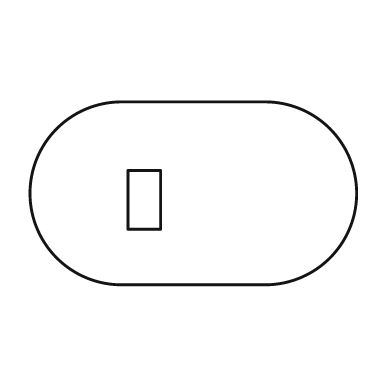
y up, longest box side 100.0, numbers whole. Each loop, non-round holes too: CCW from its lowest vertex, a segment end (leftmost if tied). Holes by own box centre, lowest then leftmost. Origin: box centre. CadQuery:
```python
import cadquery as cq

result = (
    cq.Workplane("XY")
    .moveTo(-22.0, -28.0)
    .lineTo(22.0, -28.0)
    .threePointArc((50.0, 0.0), (22.0, 28.0))
    .lineTo(-22.0, 28.0)
    .threePointArc((-50.0, 0.0), (-22.0, -28.0))
    .close()
    .moveTo(-20.0, -11.0)
    .lineTo(-10.0, -11.0)
    .lineTo(-10.0, 7.0)
    .lineTo(-20.0, 7.0)
    .close()
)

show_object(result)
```